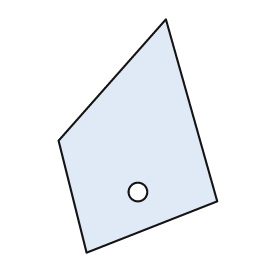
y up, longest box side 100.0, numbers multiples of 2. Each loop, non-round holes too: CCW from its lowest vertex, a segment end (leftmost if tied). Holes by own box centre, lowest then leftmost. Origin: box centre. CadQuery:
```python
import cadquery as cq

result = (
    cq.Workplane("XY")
    .moveTo(-22.0, -50.0)
    .lineTo(34.0, -28.0)
    .lineTo(12.0, 50.0)
    .lineTo(-34.0, -2.0)
    .close()
    .moveTo(0.0, -24.0)
    .circle(4.0)
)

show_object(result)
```